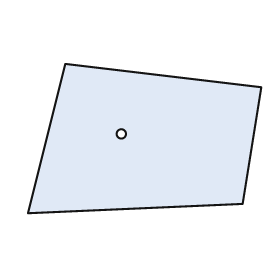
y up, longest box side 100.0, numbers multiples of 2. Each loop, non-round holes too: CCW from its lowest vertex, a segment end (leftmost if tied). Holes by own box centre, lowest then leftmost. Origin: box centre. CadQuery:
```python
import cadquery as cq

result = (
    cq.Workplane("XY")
    .moveTo(-50.0, -32.0)
    .lineTo(42.0, -28.0)
    .lineTo(50.0, 22.0)
    .lineTo(-34.0, 32.0)
    .close()
    .moveTo(-10.0, 2.0)
    .circle(2.0)
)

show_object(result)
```